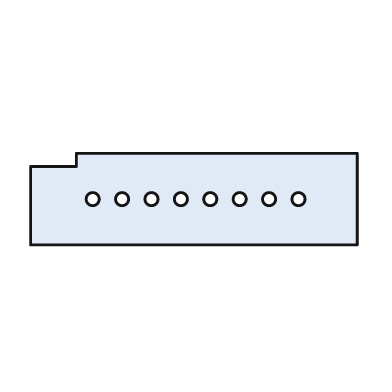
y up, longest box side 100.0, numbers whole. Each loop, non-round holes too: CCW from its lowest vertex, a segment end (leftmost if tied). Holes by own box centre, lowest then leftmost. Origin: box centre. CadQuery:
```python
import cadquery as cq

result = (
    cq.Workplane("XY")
    .moveTo(-50.0, -14.0)
    .lineTo(50.0, -14.0)
    .lineTo(50.0, 14.0)
    .lineTo(-36.0, 14.0)
    .lineTo(-36.0, 10.0)
    .lineTo(-50.0, 10.0)
    .close()
    .moveTo(-31.0, 0.0)
    .circle(2.0)
    .moveTo(-22.0, 0.0)
    .circle(2.0)
    .moveTo(-13.0, 0.0)
    .circle(2.0)
    .moveTo(-4.0, 0.0)
    .circle(2.0)
    .moveTo(5.0, 0.0)
    .circle(2.0)
    .moveTo(14.0, 0.0)
    .circle(2.0)
    .moveTo(23.0, 0.0)
    .circle(2.0)
    .moveTo(32.0, 0.0)
    .circle(2.0)
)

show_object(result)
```